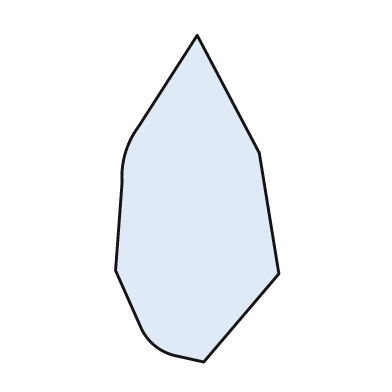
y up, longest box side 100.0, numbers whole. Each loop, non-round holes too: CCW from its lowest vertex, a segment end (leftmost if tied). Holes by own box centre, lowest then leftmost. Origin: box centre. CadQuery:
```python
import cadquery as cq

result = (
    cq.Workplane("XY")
    .moveTo(2.0, -50.0)
    .lineTo(25.0, -23.0)
    .lineTo(19.0, 14.0)
    .lineTo(0.0, 50.0)
    .lineTo(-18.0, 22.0)
    .threePointArc((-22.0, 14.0), (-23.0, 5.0))
    .lineTo(-25.0, -22.0)
    .lineTo(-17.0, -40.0)
    .threePointArc((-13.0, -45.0), (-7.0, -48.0))
    .close()
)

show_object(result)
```